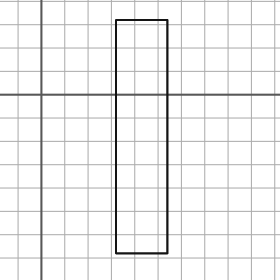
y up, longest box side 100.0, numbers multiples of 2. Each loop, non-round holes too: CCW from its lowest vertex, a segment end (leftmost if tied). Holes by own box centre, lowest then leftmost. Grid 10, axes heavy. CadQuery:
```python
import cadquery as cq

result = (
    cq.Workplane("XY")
    .moveTo(32.0, -68.0)
    .lineTo(54.0, -68.0)
    .lineTo(54.0, 32.0)
    .lineTo(32.0, 32.0)
    .close()
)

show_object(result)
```